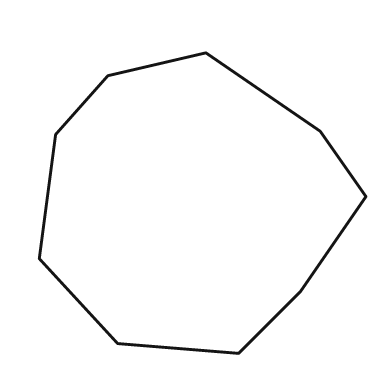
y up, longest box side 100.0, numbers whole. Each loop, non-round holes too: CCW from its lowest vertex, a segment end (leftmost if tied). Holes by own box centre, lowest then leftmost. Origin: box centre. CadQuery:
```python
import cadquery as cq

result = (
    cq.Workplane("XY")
    .moveTo(11.0, -46.0)
    .lineTo(30.0, -27.0)
    .lineTo(50.0, 2.0)
    .lineTo(36.0, 22.0)
    .lineTo(1.0, 46.0)
    .lineTo(-29.0, 39.0)
    .lineTo(-45.0, 21.0)
    .lineTo(-50.0, -17.0)
    .lineTo(-26.0, -43.0)
    .close()
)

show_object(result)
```